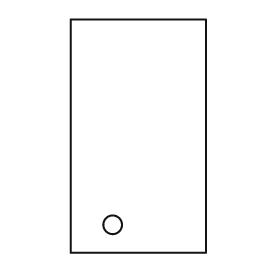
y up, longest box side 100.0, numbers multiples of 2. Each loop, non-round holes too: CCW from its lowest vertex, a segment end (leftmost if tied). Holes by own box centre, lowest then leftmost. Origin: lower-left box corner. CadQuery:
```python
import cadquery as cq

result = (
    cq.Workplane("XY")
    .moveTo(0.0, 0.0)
    .lineTo(58.0, 0.0)
    .lineTo(58.0, 100.0)
    .lineTo(0.0, 100.0)
    .close()
    .moveTo(18.0, 12.0)
    .circle(4.0)
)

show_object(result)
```